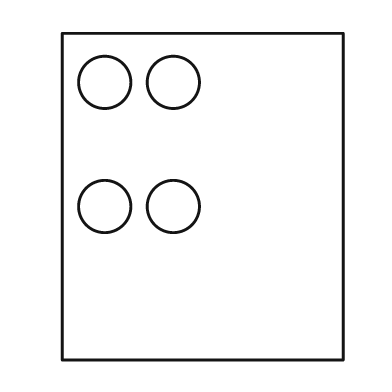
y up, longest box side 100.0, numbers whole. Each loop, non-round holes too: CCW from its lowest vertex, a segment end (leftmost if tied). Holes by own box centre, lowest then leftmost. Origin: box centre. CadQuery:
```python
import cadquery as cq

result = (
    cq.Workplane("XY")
    .moveTo(-43.0, -50.0)
    .lineTo(43.0, -50.0)
    .lineTo(43.0, 50.0)
    .lineTo(-43.0, 50.0)
    .close()
    .moveTo(-30.0, -3.0)
    .circle(8.0)
    .moveTo(-9.0, -3.0)
    .circle(8.0)
    .moveTo(-30.0, 35.0)
    .circle(8.0)
    .moveTo(-9.0, 35.0)
    .circle(8.0)
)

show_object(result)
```